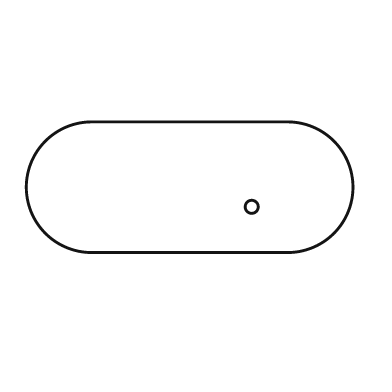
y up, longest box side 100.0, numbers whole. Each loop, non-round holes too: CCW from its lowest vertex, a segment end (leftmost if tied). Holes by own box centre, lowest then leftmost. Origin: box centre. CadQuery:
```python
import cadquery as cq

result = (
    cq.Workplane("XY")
    .moveTo(-30.0, -20.0)
    .lineTo(30.0, -20.0)
    .threePointArc((50.0, 0.0), (30.0, 20.0))
    .lineTo(-30.0, 20.0)
    .threePointArc((-50.0, 0.0), (-30.0, -20.0))
    .close()
    .moveTo(19.0, -6.0)
    .circle(2.0)
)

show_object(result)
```